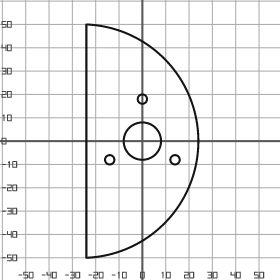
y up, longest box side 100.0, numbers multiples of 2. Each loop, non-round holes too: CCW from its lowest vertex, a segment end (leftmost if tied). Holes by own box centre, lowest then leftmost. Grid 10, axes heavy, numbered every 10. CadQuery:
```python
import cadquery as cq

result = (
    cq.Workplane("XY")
    .moveTo(-24.0, -50.0)
    .threePointArc((24.0, 0.0), (-24.0, 50.0))
    .close()
    .moveTo(-14.0, -8.0)
    .circle(2.0)
    .moveTo(14.0, -8.0)
    .circle(2.0)
    .moveTo(0.0, 0.0)
    .circle(8.0)
    .moveTo(0.0, 18.0)
    .circle(2.0)
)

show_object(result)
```